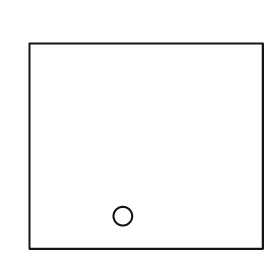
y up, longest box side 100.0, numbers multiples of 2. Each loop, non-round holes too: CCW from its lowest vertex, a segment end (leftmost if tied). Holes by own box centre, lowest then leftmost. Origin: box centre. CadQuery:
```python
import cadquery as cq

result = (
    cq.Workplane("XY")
    .moveTo(-50.0, -44.0)
    .lineTo(50.0, -44.0)
    .lineTo(50.0, 44.0)
    .lineTo(-50.0, 44.0)
    .close()
    .moveTo(-10.0, -30.0)
    .circle(4.0)
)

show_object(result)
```